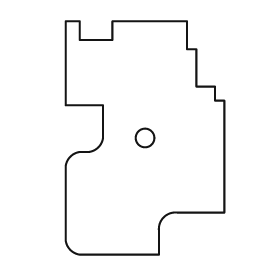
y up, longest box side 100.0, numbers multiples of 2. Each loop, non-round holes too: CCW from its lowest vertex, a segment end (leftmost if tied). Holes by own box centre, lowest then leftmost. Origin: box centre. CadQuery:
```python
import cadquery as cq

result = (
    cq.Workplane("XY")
    .moveTo(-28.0, -50.0)
    .lineTo(6.0, -50.0)
    .lineTo(6.0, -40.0)
    .threePointArc((8.0, -34.0), (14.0, -32.0))
    .lineTo(34.0, -32.0)
    .lineTo(34.0, 16.0)
    .lineTo(30.0, 16.0)
    .lineTo(30.0, 22.0)
    .lineTo(22.0, 22.0)
    .lineTo(22.0, 38.0)
    .lineTo(18.0, 38.0)
    .lineTo(18.0, 50.0)
    .lineTo(-14.0, 50.0)
    .lineTo(-14.0, 42.0)
    .lineTo(-28.0, 42.0)
    .lineTo(-28.0, 50.0)
    .lineTo(-34.0, 50.0)
    .lineTo(-34.0, 14.0)
    .lineTo(-18.0, 14.0)
    .lineTo(-18.0, 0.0)
    .threePointArc((-20.0, -4.0), (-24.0, -6.0))
    .lineTo(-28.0, -6.0)
    .threePointArc((-32.0, -8.0), (-34.0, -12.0))
    .lineTo(-34.0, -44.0)
    .threePointArc((-32.0, -48.0), (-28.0, -50.0))
    .close()
    .moveTo(0.0, 0.0)
    .circle(4.0)
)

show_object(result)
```